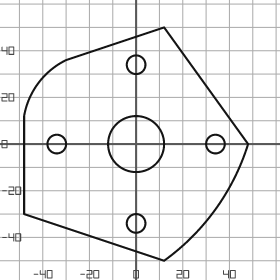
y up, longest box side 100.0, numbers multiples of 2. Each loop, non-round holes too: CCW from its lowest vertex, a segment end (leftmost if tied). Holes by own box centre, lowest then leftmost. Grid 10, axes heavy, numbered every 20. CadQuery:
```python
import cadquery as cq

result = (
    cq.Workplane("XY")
    .moveTo(12.0, -50.0)
    .threePointArc((34.0, -28.0), (48.0, 0.0))
    .lineTo(12.0, 50.0)
    .lineTo(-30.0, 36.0)
    .threePointArc((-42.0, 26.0), (-48.0, 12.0))
    .lineTo(-48.0, -30.0)
    .close()
    .moveTo(0.0, -34.0)
    .circle(4.0)
    .moveTo(-34.0, 0.0)
    .circle(4.0)
    .moveTo(0.0, 0.0)
    .circle(12.0)
    .moveTo(34.0, 0.0)
    .circle(4.0)
    .moveTo(0.0, 34.0)
    .circle(4.0)
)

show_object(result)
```